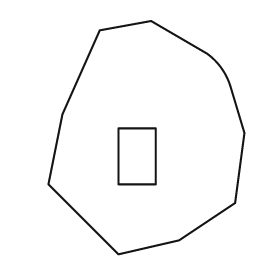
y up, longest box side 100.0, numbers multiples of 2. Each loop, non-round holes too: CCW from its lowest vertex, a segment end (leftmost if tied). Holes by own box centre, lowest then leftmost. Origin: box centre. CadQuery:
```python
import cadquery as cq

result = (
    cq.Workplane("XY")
    .moveTo(-12.0, -50.0)
    .lineTo(14.0, -44.0)
    .lineTo(38.0, -28.0)
    .lineTo(42.0, 2.0)
    .lineTo(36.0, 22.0)
    .threePointArc((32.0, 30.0), (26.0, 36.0))
    .lineTo(2.0, 50.0)
    .lineTo(-20.0, 46.0)
    .lineTo(-36.0, 10.0)
    .lineTo(-42.0, -20.0)
    .close()
    .moveTo(-12.0, -20.0)
    .lineTo(4.0, -20.0)
    .lineTo(4.0, 4.0)
    .lineTo(-12.0, 4.0)
    .close()
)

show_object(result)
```